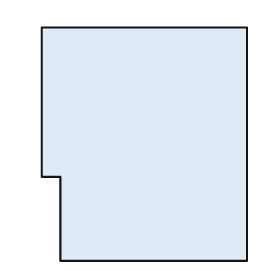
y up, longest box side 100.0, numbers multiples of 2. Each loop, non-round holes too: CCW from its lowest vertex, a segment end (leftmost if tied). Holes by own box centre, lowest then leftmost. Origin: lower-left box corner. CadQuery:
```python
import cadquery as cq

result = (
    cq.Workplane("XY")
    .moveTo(8.0, 0.0)
    .lineTo(88.0, 0.0)
    .lineTo(88.0, 100.0)
    .lineTo(0.0, 100.0)
    .lineTo(0.0, 36.0)
    .lineTo(8.0, 36.0)
    .close()
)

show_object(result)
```